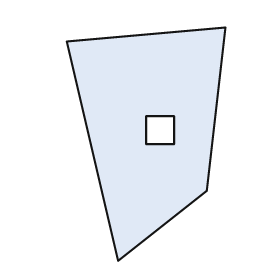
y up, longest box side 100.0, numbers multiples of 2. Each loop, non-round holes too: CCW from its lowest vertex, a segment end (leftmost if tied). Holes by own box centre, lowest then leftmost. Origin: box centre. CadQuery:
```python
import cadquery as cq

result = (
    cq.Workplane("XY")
    .moveTo(-12.0, -50.0)
    .lineTo(26.0, -20.0)
    .lineTo(34.0, 50.0)
    .lineTo(-34.0, 44.0)
    .close()
    .moveTo(0.0, 0.0)
    .lineTo(12.0, 0.0)
    .lineTo(12.0, 12.0)
    .lineTo(0.0, 12.0)
    .close()
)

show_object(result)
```